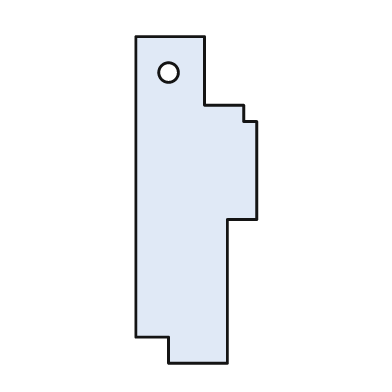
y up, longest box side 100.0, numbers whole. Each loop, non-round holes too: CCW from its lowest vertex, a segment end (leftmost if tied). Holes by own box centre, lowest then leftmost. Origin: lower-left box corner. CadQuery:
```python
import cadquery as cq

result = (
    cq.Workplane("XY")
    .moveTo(10.0, 0.0)
    .lineTo(28.0, 0.0)
    .lineTo(28.0, 44.0)
    .lineTo(37.0, 44.0)
    .lineTo(37.0, 74.0)
    .lineTo(33.0, 74.0)
    .lineTo(33.0, 79.0)
    .lineTo(21.0, 79.0)
    .lineTo(21.0, 100.0)
    .lineTo(0.0, 100.0)
    .lineTo(0.0, 8.0)
    .lineTo(10.0, 8.0)
    .close()
    .moveTo(10.0, 89.0)
    .circle(3.0)
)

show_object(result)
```